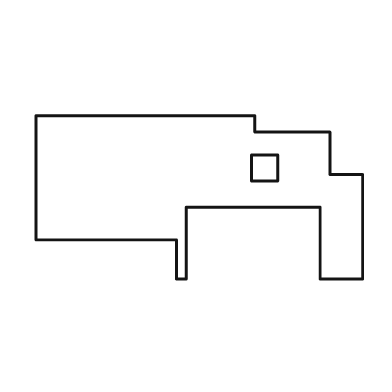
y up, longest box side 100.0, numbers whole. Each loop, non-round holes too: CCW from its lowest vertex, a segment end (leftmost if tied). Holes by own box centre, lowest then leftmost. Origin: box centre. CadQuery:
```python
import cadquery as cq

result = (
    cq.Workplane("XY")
    .moveTo(-7.0, -25.0)
    .lineTo(-4.0, -25.0)
    .lineTo(-4.0, -3.0)
    .lineTo(37.0, -3.0)
    .lineTo(37.0, -25.0)
    .lineTo(50.0, -25.0)
    .lineTo(50.0, 7.0)
    .lineTo(40.0, 7.0)
    .lineTo(40.0, 20.0)
    .lineTo(17.0, 20.0)
    .lineTo(17.0, 25.0)
    .lineTo(-50.0, 25.0)
    .lineTo(-50.0, -13.0)
    .lineTo(-7.0, -13.0)
    .close()
    .moveTo(16.0, 5.0)
    .lineTo(24.0, 5.0)
    .lineTo(24.0, 13.0)
    .lineTo(16.0, 13.0)
    .close()
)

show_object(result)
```